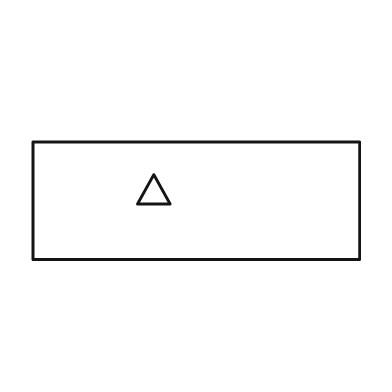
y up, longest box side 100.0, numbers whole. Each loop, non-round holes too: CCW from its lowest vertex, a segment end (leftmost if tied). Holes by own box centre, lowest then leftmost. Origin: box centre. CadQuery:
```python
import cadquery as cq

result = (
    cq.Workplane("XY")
    .moveTo(-50.0, -18.0)
    .lineTo(50.0, -18.0)
    .lineTo(50.0, 18.0)
    .lineTo(-50.0, 18.0)
    .close()
    .moveTo(-18.0, -1.0)
    .lineTo(-8.0, -1.0)
    .lineTo(-13.0, 8.0)
    .close()
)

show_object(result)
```